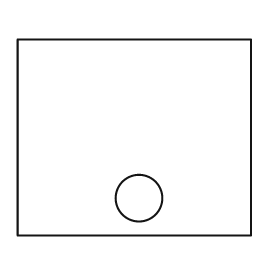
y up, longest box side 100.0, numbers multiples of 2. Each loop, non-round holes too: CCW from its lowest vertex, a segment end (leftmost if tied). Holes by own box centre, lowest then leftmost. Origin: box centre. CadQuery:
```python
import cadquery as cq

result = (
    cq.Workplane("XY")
    .moveTo(-50.0, -42.0)
    .lineTo(50.0, -42.0)
    .lineTo(50.0, 42.0)
    .lineTo(-50.0, 42.0)
    .close()
    .moveTo(2.0, -26.0)
    .circle(10.0)
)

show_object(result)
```